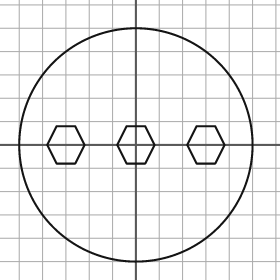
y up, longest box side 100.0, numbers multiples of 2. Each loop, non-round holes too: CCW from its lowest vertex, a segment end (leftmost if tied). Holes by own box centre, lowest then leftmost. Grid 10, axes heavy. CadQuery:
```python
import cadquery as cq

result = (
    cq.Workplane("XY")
    .moveTo(0.0, 0.0)
    .circle(50.0)
    .moveTo(-34.0, -8.0)
    .lineTo(-26.0, -8.0)
    .lineTo(-22.0, 0.0)
    .lineTo(-26.0, 8.0)
    .lineTo(-34.0, 8.0)
    .lineTo(-38.0, 0.0)
    .close()
    .moveTo(-4.0, -8.0)
    .lineTo(4.0, -8.0)
    .lineTo(8.0, 0.0)
    .lineTo(4.0, 8.0)
    .lineTo(-4.0, 8.0)
    .lineTo(-8.0, 0.0)
    .close()
    .moveTo(26.0, -8.0)
    .lineTo(34.0, -8.0)
    .lineTo(38.0, 0.0)
    .lineTo(34.0, 8.0)
    .lineTo(26.0, 8.0)
    .lineTo(22.0, 0.0)
    .close()
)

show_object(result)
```